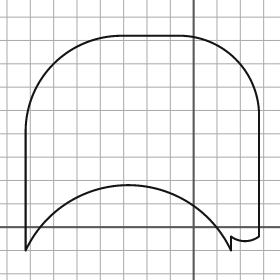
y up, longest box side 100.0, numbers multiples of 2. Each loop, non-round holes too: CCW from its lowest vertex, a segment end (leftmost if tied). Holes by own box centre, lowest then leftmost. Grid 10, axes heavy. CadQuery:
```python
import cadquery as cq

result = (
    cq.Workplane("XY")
    .moveTo(-72.0, -10.0)
    .threePointArc((-28.0, 18.0), (16.0, -10.0))
    .lineTo(16.0, -4.0)
    .threePointArc((22.0, -6.0), (28.0, -4.0))
    .lineTo(28.0, 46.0)
    .threePointArc((18.0, 72.0), (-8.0, 82.0))
    .lineTo(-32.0, 82.0)
    .threePointArc((-60.0, 70.0), (-72.0, 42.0))
    .close()
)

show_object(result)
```